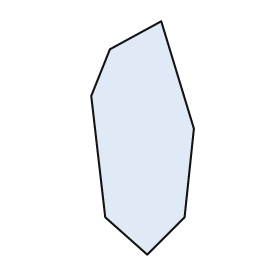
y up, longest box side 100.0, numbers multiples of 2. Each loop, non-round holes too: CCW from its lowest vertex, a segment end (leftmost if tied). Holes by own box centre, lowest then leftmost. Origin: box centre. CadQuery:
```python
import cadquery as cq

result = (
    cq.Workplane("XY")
    .moveTo(2.0, -50.0)
    .lineTo(18.0, -34.0)
    .lineTo(22.0, 4.0)
    .lineTo(8.0, 50.0)
    .lineTo(-14.0, 38.0)
    .lineTo(-22.0, 18.0)
    .lineTo(-16.0, -34.0)
    .close()
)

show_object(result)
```